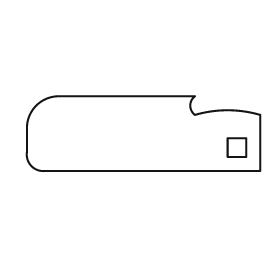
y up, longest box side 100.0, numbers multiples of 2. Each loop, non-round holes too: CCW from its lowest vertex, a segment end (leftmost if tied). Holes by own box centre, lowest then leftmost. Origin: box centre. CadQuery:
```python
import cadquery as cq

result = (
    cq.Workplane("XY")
    .moveTo(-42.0, -16.0)
    .lineTo(50.0, -16.0)
    .lineTo(50.0, 8.0)
    .threePointArc((36.0, 10.0), (22.0, 8.0))
    .threePointArc((20.0, 12.0), (22.0, 16.0))
    .lineTo(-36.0, 16.0)
    .threePointArc((-46.0, 12.0), (-50.0, 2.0))
    .lineTo(-50.0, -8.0)
    .threePointArc((-48.0, -14.0), (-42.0, -16.0))
    .close()
    .moveTo(36.0, -10.0)
    .lineTo(44.0, -10.0)
    .lineTo(44.0, -2.0)
    .lineTo(36.0, -2.0)
    .close()
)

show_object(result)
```